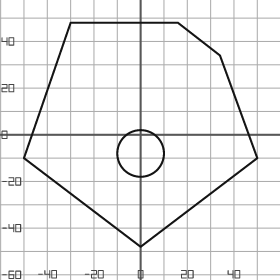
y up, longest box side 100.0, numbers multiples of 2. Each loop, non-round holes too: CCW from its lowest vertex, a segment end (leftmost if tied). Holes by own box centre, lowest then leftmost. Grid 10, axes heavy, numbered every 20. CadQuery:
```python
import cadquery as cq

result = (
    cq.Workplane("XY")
    .moveTo(0.0, -48.0)
    .lineTo(50.0, -10.0)
    .lineTo(34.0, 34.0)
    .lineTo(16.0, 48.0)
    .lineTo(-30.0, 48.0)
    .lineTo(-50.0, -10.0)
    .close()
    .moveTo(0.0, -8.0)
    .circle(10.0)
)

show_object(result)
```